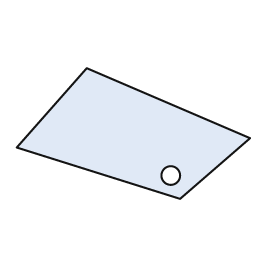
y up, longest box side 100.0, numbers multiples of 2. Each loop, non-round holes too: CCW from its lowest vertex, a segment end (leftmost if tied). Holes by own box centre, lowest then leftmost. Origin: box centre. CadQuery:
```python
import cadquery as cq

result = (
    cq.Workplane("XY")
    .moveTo(20.0, -28.0)
    .lineTo(50.0, -2.0)
    .lineTo(-20.0, 28.0)
    .lineTo(-50.0, -6.0)
    .close()
    .moveTo(16.0, -18.0)
    .circle(4.0)
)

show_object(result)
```